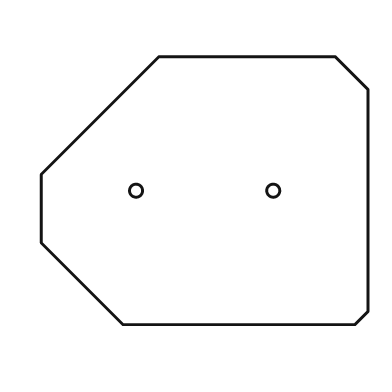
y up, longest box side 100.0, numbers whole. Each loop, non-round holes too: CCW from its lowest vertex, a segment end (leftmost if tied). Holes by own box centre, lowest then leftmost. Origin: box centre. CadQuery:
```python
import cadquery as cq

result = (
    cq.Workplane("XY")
    .moveTo(-25.0, -41.0)
    .lineTo(46.0, -41.0)
    .lineTo(50.0, -37.0)
    .lineTo(50.0, 31.0)
    .lineTo(40.0, 41.0)
    .lineTo(-14.0, 41.0)
    .lineTo(-50.0, 5.0)
    .lineTo(-50.0, -16.0)
    .close()
    .moveTo(-21.0, 0.0)
    .circle(2.0)
    .moveTo(21.0, 0.0)
    .circle(2.0)
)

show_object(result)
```